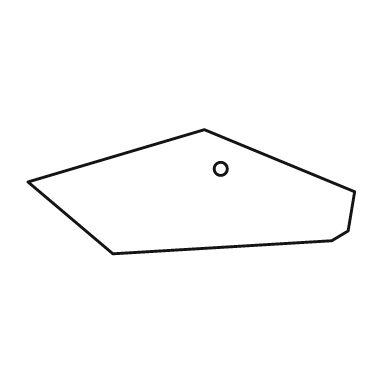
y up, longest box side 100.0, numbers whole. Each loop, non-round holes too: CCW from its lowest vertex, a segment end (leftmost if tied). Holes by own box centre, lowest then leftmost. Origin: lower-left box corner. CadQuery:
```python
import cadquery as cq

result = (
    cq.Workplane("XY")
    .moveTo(26.0, 0.0)
    .lineTo(93.0, 4.0)
    .lineTo(98.0, 7.0)
    .lineTo(100.0, 19.0)
    .lineTo(54.0, 38.0)
    .lineTo(0.0, 22.0)
    .close()
    .moveTo(59.0, 26.0)
    .circle(2.0)
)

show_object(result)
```